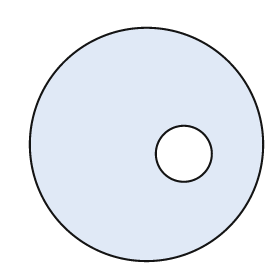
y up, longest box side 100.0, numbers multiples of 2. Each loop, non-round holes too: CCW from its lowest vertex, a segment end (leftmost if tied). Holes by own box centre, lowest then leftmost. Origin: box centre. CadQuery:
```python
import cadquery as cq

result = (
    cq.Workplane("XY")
    .moveTo(0.0, 0.0)
    .circle(50.0)
    .moveTo(16.0, -4.0)
    .circle(12.0)
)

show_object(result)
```